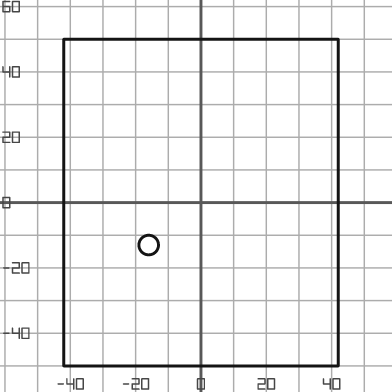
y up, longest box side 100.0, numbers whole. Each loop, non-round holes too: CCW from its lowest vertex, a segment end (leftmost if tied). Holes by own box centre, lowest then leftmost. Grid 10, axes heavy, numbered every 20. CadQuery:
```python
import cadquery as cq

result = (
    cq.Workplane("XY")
    .moveTo(-42.0, -50.0)
    .lineTo(42.0, -50.0)
    .lineTo(42.0, 50.0)
    .lineTo(-42.0, 50.0)
    .close()
    .moveTo(-16.0, -13.0)
    .circle(3.0)
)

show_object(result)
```